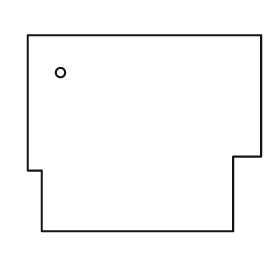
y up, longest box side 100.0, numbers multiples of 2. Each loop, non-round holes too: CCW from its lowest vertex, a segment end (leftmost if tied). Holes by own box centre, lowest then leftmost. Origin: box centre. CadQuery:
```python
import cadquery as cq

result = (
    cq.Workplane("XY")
    .moveTo(-44.0, -42.0)
    .lineTo(38.0, -42.0)
    .lineTo(38.0, -10.0)
    .lineTo(50.0, -10.0)
    .lineTo(50.0, 42.0)
    .lineTo(-50.0, 42.0)
    .lineTo(-50.0, -16.0)
    .lineTo(-44.0, -16.0)
    .close()
    .moveTo(-36.0, 26.0)
    .circle(2.0)
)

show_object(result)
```